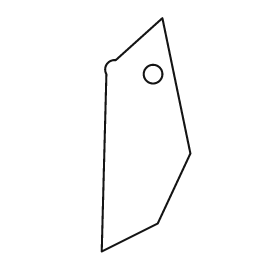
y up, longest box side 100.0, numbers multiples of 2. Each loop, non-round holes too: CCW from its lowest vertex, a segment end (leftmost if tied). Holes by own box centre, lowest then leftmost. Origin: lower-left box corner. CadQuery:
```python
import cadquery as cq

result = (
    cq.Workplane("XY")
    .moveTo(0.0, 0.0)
    .lineTo(24.0, 12.0)
    .lineTo(38.0, 42.0)
    .lineTo(26.0, 100.0)
    .lineTo(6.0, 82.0)
    .threePointArc((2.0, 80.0), (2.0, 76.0))
    .close()
    .moveTo(22.0, 76.0)
    .circle(4.0)
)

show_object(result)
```